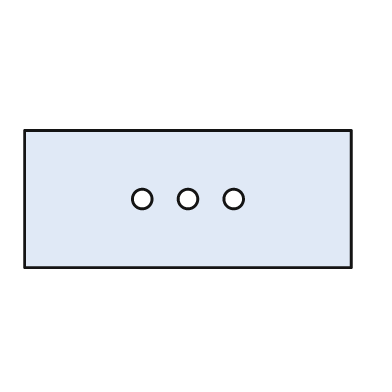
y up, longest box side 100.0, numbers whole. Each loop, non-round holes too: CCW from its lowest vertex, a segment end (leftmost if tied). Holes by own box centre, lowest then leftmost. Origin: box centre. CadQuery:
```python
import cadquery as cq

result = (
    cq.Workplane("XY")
    .moveTo(-50.0, -21.0)
    .lineTo(50.0, -21.0)
    .lineTo(50.0, 21.0)
    .lineTo(-50.0, 21.0)
    .close()
    .moveTo(-14.0, 0.0)
    .circle(3.0)
    .moveTo(0.0, 0.0)
    .circle(3.0)
    .moveTo(14.0, 0.0)
    .circle(3.0)
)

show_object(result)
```